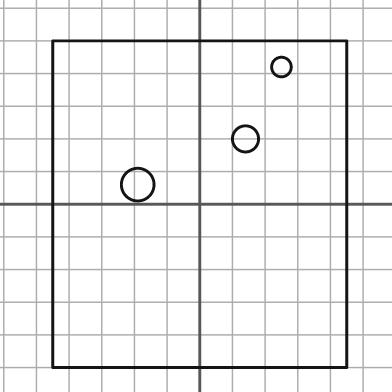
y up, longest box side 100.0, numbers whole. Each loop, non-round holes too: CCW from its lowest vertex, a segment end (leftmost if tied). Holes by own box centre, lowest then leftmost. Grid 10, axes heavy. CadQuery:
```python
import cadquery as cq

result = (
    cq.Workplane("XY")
    .moveTo(-45.0, -50.0)
    .lineTo(45.0, -50.0)
    .lineTo(45.0, 50.0)
    .lineTo(-45.0, 50.0)
    .close()
    .moveTo(-19.0, 6.0)
    .circle(5.0)
    .moveTo(14.0, 20.0)
    .circle(4.0)
    .moveTo(25.0, 42.0)
    .circle(3.0)
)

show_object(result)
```